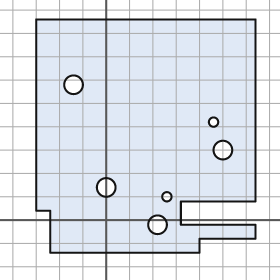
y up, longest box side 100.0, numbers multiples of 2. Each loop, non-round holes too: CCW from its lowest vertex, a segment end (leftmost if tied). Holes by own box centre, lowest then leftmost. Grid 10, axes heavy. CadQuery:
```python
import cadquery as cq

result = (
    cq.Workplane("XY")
    .moveTo(-24.0, -14.0)
    .lineTo(40.0, -14.0)
    .lineTo(40.0, -8.0)
    .lineTo(64.0, -8.0)
    .lineTo(64.0, -2.0)
    .lineTo(32.0, -2.0)
    .lineTo(32.0, 8.0)
    .lineTo(64.0, 8.0)
    .lineTo(64.0, 86.0)
    .lineTo(-30.0, 86.0)
    .lineTo(-30.0, 4.0)
    .lineTo(-24.0, 4.0)
    .close()
    .moveTo(22.0, -2.0)
    .circle(4.0)
    .moveTo(26.0, 10.0)
    .circle(2.0)
    .moveTo(0.0, 14.0)
    .circle(4.0)
    .moveTo(50.0, 30.0)
    .circle(4.0)
    .moveTo(46.0, 42.0)
    .circle(2.0)
    .moveTo(-14.0, 58.0)
    .circle(4.0)
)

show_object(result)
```